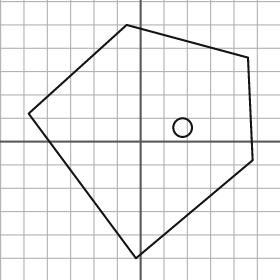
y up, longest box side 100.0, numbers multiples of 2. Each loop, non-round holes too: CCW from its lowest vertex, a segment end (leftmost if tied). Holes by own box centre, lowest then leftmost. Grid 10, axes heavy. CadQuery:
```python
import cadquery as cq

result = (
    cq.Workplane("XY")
    .moveTo(-2.0, -50.0)
    .lineTo(48.0, -8.0)
    .lineTo(46.0, 36.0)
    .lineTo(-6.0, 50.0)
    .lineTo(-48.0, 12.0)
    .close()
    .moveTo(18.0, 6.0)
    .circle(4.0)
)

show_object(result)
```